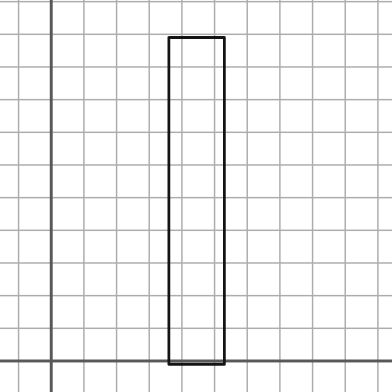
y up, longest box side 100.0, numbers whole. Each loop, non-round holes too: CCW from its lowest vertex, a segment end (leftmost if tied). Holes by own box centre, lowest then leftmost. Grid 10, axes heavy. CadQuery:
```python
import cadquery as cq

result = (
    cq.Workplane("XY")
    .moveTo(36.0, -1.0)
    .lineTo(53.0, -1.0)
    .lineTo(53.0, 99.0)
    .lineTo(36.0, 99.0)
    .close()
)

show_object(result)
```